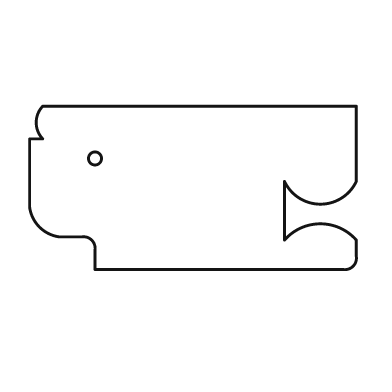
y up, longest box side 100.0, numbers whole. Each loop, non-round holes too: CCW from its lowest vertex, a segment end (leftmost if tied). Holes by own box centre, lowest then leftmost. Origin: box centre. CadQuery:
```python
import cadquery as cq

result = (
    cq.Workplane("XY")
    .moveTo(-30.0, -25.0)
    .lineTo(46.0, -25.0)
    .threePointArc((49.0, -24.0), (50.0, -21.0))
    .lineTo(50.0, -16.0)
    .threePointArc((39.0, -11.0), (28.0, -16.0))
    .lineTo(28.0, 2.0)
    .threePointArc((39.0, -5.0), (50.0, 2.0))
    .lineTo(50.0, 25.0)
    .lineTo(-46.0, 25.0)
    .threePointArc((-48.0, 20.0), (-46.0, 15.0))
    .lineTo(-50.0, 15.0)
    .lineTo(-50.0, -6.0)
    .threePointArc((-47.0, -12.0), (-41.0, -15.0))
    .lineTo(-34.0, -15.0)
    .threePointArc((-31.0, -16.0), (-30.0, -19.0))
    .close()
    .moveTo(-30.0, 9.0)
    .circle(2.0)
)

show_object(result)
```